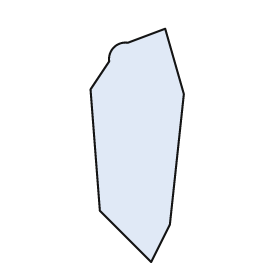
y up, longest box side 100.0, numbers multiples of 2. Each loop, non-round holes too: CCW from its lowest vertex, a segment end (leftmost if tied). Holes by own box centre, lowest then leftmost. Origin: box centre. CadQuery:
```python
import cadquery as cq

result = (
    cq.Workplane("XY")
    .moveTo(6.0, -50.0)
    .lineTo(14.0, -34.0)
    .lineTo(20.0, 22.0)
    .lineTo(12.0, 50.0)
    .lineTo(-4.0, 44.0)
    .threePointArc((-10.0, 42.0), (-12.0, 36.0))
    .lineTo(-20.0, 24.0)
    .lineTo(-16.0, -28.0)
    .close()
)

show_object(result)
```